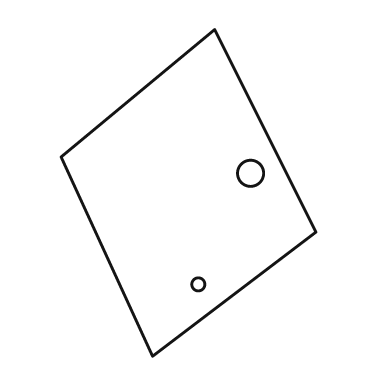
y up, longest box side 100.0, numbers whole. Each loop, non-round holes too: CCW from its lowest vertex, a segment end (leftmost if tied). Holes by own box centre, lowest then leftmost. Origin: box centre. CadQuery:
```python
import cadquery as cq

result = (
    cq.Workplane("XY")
    .moveTo(-11.0, -50.0)
    .lineTo(39.0, -12.0)
    .lineTo(8.0, 50.0)
    .lineTo(-39.0, 11.0)
    .close()
    .moveTo(3.0, -28.0)
    .circle(2.0)
    .moveTo(19.0, 6.0)
    .circle(4.0)
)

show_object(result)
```